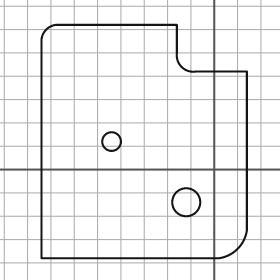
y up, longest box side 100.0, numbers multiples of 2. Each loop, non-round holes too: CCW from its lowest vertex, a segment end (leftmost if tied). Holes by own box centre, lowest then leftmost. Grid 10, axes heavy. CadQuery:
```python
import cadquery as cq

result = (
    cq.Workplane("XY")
    .moveTo(-74.0, -38.0)
    .lineTo(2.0, -38.0)
    .threePointArc((10.0, -34.0), (14.0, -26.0))
    .lineTo(14.0, 42.0)
    .lineTo(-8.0, 42.0)
    .threePointArc((-14.0, 44.0), (-16.0, 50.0))
    .lineTo(-16.0, 62.0)
    .lineTo(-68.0, 62.0)
    .threePointArc((-72.0, 60.0), (-74.0, 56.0))
    .close()
    .moveTo(-12.0, -14.0)
    .circle(6.0)
    .moveTo(-44.0, 12.0)
    .circle(4.0)
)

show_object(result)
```